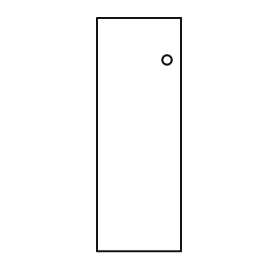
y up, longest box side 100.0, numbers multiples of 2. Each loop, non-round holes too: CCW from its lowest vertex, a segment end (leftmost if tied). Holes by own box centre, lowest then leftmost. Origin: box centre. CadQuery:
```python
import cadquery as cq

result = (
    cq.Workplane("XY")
    .moveTo(-18.0, -50.0)
    .lineTo(18.0, -50.0)
    .lineTo(18.0, 50.0)
    .lineTo(-18.0, 50.0)
    .close()
    .moveTo(12.0, 32.0)
    .circle(2.0)
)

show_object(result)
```